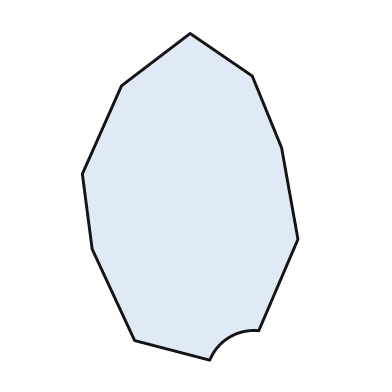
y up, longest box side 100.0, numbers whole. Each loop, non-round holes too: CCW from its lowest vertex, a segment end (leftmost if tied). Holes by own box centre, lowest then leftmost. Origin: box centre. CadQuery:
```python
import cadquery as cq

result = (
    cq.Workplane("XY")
    .moveTo(6.0, -50.0)
    .threePointArc((12.0, -43.0), (21.0, -41.0))
    .lineTo(33.0, -13.0)
    .lineTo(28.0, 15.0)
    .lineTo(19.0, 37.0)
    .lineTo(0.0, 50.0)
    .lineTo(-21.0, 34.0)
    .lineTo(-33.0, 7.0)
    .lineTo(-30.0, -16.0)
    .lineTo(-17.0, -44.0)
    .close()
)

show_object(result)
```